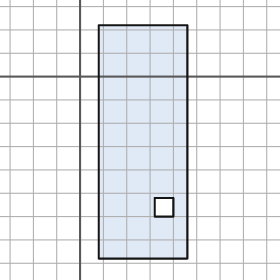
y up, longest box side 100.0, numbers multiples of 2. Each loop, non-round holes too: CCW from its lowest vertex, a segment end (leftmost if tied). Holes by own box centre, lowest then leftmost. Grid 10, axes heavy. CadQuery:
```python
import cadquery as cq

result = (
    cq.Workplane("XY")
    .moveTo(8.0, -78.0)
    .lineTo(46.0, -78.0)
    .lineTo(46.0, 22.0)
    .lineTo(8.0, 22.0)
    .close()
    .moveTo(32.0, -60.0)
    .lineTo(40.0, -60.0)
    .lineTo(40.0, -52.0)
    .lineTo(32.0, -52.0)
    .close()
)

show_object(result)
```